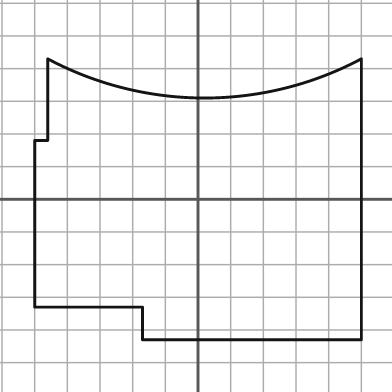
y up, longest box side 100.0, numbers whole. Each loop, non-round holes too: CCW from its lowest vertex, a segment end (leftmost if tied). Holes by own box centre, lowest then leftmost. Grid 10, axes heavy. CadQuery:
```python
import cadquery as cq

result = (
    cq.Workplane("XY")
    .moveTo(-17.0, -43.0)
    .lineTo(50.0, -43.0)
    .lineTo(50.0, 43.0)
    .threePointArc((2.0, 31.0), (-46.0, 43.0))
    .lineTo(-46.0, 18.0)
    .lineTo(-50.0, 18.0)
    .lineTo(-50.0, -33.0)
    .lineTo(-17.0, -33.0)
    .close()
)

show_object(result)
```